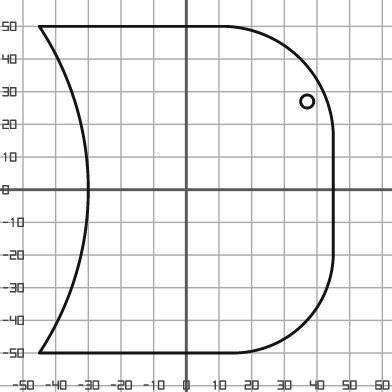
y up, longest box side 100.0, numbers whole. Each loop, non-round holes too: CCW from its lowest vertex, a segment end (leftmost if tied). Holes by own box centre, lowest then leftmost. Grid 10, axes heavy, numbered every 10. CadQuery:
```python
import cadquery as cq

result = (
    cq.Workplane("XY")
    .moveTo(-45.0, -50.0)
    .lineTo(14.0, -50.0)
    .threePointArc((36.0, -41.0), (45.0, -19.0))
    .lineTo(45.0, 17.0)
    .threePointArc((35.0, 40.0), (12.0, 50.0))
    .lineTo(-45.0, 50.0)
    .threePointArc((-30.0, 0.0), (-45.0, -50.0))
    .close()
    .moveTo(37.0, 27.0)
    .circle(2.0)
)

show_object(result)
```